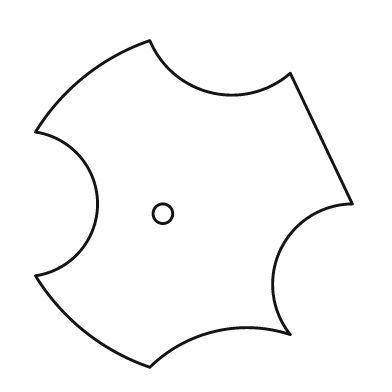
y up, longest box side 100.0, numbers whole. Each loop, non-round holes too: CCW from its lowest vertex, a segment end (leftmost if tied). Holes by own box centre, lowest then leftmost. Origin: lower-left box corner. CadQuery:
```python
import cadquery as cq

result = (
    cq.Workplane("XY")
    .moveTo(35.0, 0.0)
    .threePointArc((55.0, 11.0), (78.0, 10.0))
    .threePointArc((75.0, 36.0), (97.0, 50.0))
    .lineTo(78.0, 90.0)
    .threePointArc((54.0, 84.0), (35.0, 100.0))
    .threePointArc((15.0, 89.0), (0.0, 72.0))
    .threePointArc((19.0, 50.0), (0.0, 28.0))
    .threePointArc((15.0, 11.0), (35.0, 0.0))
    .close()
    .moveTo(39.0, 47.0)
    .circle(3.0)
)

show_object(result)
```